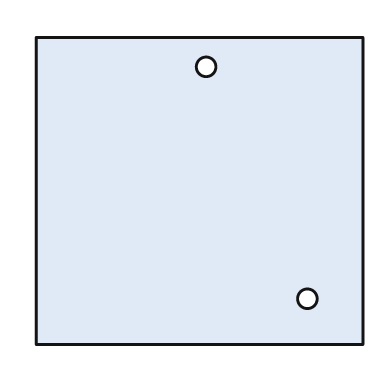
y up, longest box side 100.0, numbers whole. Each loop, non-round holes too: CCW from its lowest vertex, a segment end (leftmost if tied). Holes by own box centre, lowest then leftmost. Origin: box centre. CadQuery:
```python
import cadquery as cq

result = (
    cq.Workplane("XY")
    .moveTo(-50.0, -47.0)
    .lineTo(50.0, -47.0)
    .lineTo(50.0, 47.0)
    .lineTo(-50.0, 47.0)
    .close()
    .moveTo(33.0, -33.0)
    .circle(3.0)
    .moveTo(2.0, 38.0)
    .circle(3.0)
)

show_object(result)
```